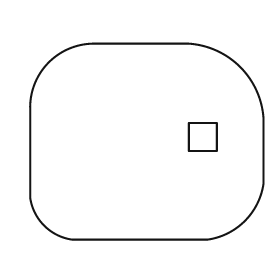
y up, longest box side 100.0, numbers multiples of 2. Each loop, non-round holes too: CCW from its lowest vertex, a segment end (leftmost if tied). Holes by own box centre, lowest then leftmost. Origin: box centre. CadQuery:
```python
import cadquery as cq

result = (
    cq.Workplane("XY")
    .moveTo(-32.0, -42.0)
    .lineTo(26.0, -42.0)
    .threePointArc((42.0, -34.0), (50.0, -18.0))
    .lineTo(50.0, 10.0)
    .threePointArc((40.0, 32.0), (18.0, 42.0))
    .lineTo(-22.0, 42.0)
    .threePointArc((-42.0, 34.0), (-50.0, 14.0))
    .lineTo(-50.0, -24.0)
    .threePointArc((-44.0, -36.0), (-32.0, -42.0))
    .close()
    .moveTo(18.0, -4.0)
    .lineTo(30.0, -4.0)
    .lineTo(30.0, 8.0)
    .lineTo(18.0, 8.0)
    .close()
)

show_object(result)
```